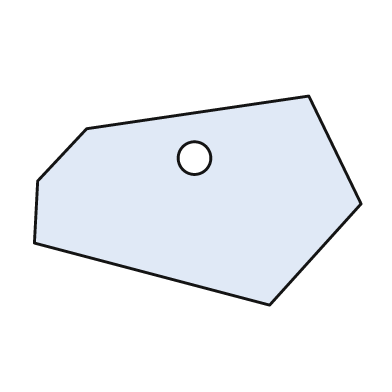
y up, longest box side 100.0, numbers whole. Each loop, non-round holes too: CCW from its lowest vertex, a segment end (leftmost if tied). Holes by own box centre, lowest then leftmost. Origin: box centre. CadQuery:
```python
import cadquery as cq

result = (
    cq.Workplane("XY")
    .moveTo(22.0, -32.0)
    .lineTo(50.0, -1.0)
    .lineTo(34.0, 32.0)
    .lineTo(-34.0, 22.0)
    .lineTo(-49.0, 6.0)
    .lineTo(-50.0, -13.0)
    .close()
    .moveTo(-1.0, 13.0)
    .circle(5.0)
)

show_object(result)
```